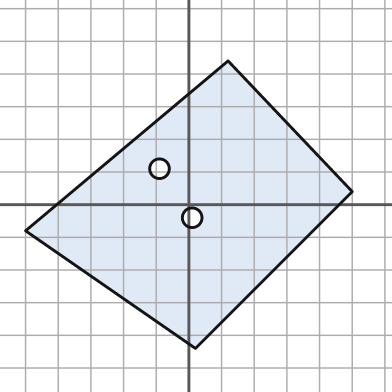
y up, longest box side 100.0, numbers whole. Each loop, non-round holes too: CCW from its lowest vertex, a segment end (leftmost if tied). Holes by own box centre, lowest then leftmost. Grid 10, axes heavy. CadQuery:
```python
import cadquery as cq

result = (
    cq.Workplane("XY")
    .moveTo(2.0, -44.0)
    .lineTo(50.0, 4.0)
    .lineTo(12.0, 44.0)
    .lineTo(-50.0, -8.0)
    .close()
    .moveTo(1.0, -4.0)
    .circle(3.0)
    .moveTo(-9.0, 11.0)
    .circle(3.0)
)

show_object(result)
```